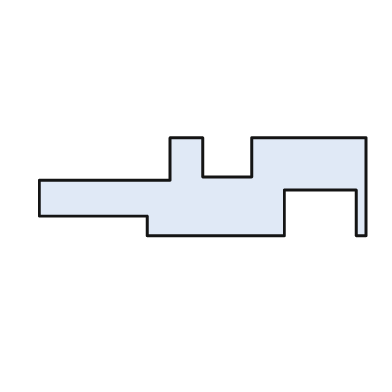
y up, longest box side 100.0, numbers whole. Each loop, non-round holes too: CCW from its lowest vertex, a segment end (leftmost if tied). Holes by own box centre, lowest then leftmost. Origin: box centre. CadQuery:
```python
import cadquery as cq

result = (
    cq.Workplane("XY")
    .moveTo(-17.0, -15.0)
    .lineTo(25.0, -15.0)
    .lineTo(25.0, -1.0)
    .lineTo(47.0, -1.0)
    .lineTo(47.0, -15.0)
    .lineTo(50.0, -15.0)
    .lineTo(50.0, 15.0)
    .lineTo(15.0, 15.0)
    .lineTo(15.0, 3.0)
    .lineTo(0.0, 3.0)
    .lineTo(0.0, 15.0)
    .lineTo(-10.0, 15.0)
    .lineTo(-10.0, 2.0)
    .lineTo(-50.0, 2.0)
    .lineTo(-50.0, -9.0)
    .lineTo(-17.0, -9.0)
    .close()
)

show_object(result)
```